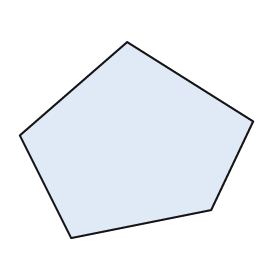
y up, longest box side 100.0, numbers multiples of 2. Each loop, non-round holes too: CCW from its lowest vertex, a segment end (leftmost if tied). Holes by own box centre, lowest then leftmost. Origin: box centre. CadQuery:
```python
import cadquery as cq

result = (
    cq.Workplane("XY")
    .moveTo(-28.0, -42.0)
    .lineTo(32.0, -30.0)
    .lineTo(50.0, 8.0)
    .lineTo(-4.0, 42.0)
    .lineTo(-50.0, 2.0)
    .close()
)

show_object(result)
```